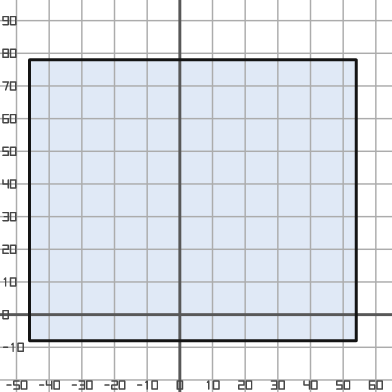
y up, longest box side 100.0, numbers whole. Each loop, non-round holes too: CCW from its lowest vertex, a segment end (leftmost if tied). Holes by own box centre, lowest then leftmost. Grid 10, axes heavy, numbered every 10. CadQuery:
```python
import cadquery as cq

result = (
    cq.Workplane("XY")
    .moveTo(-46.0, -8.0)
    .lineTo(54.0, -8.0)
    .lineTo(54.0, 78.0)
    .lineTo(-46.0, 78.0)
    .close()
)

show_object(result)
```